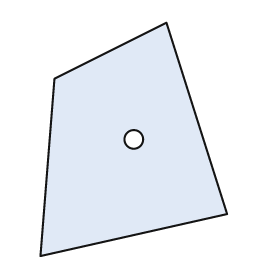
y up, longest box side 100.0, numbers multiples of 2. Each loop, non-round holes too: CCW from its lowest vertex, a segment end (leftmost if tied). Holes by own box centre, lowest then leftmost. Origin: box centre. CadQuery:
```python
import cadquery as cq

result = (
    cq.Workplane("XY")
    .moveTo(-40.0, -50.0)
    .lineTo(40.0, -32.0)
    .lineTo(14.0, 50.0)
    .lineTo(-34.0, 26.0)
    .close()
    .moveTo(0.0, 0.0)
    .circle(4.0)
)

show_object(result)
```